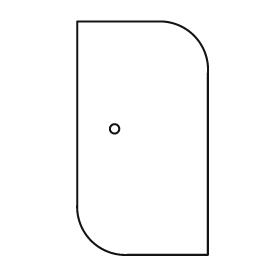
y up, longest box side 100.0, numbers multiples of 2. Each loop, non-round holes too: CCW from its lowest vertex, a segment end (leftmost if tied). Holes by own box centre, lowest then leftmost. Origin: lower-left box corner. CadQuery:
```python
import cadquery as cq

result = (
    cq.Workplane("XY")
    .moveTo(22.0, 0.0)
    .lineTo(56.0, 0.0)
    .lineTo(56.0, 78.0)
    .threePointArc((50.0, 94.0), (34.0, 100.0))
    .lineTo(0.0, 100.0)
    .lineTo(0.0, 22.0)
    .threePointArc((6.0, 6.0), (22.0, 0.0))
    .close()
    .moveTo(16.0, 54.0)
    .circle(2.0)
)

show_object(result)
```